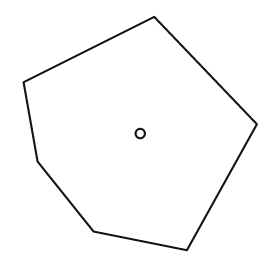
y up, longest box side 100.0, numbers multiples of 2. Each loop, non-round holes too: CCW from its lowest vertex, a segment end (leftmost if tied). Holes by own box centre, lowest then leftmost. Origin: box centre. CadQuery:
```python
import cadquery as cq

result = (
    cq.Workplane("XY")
    .moveTo(20.0, -50.0)
    .lineTo(50.0, 4.0)
    .lineTo(6.0, 50.0)
    .lineTo(-50.0, 22.0)
    .lineTo(-44.0, -12.0)
    .lineTo(-20.0, -42.0)
    .close()
    .moveTo(0.0, 0.0)
    .circle(2.0)
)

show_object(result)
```